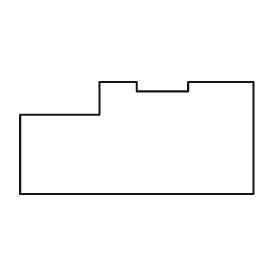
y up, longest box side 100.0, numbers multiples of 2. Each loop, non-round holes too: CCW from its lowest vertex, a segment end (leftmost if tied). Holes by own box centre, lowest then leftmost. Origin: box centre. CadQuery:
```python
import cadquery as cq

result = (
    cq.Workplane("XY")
    .moveTo(-50.0, -24.0)
    .lineTo(50.0, -24.0)
    .lineTo(50.0, 24.0)
    .lineTo(22.0, 24.0)
    .lineTo(22.0, 20.0)
    .lineTo(0.0, 20.0)
    .lineTo(0.0, 24.0)
    .lineTo(-16.0, 24.0)
    .lineTo(-16.0, 10.0)
    .lineTo(-50.0, 10.0)
    .close()
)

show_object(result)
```